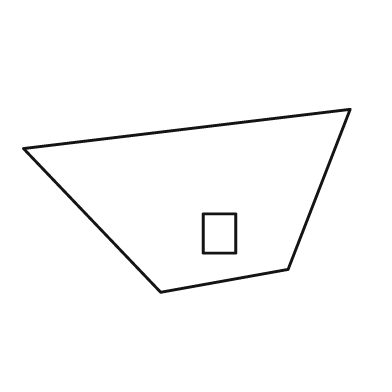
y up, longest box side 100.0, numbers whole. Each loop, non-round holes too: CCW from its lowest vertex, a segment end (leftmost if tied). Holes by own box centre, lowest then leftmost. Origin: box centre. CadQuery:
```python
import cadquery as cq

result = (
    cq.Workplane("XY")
    .moveTo(-8.0, -28.0)
    .lineTo(31.0, -21.0)
    .lineTo(50.0, 28.0)
    .lineTo(-50.0, 16.0)
    .close()
    .moveTo(5.0, -16.0)
    .lineTo(15.0, -16.0)
    .lineTo(15.0, -4.0)
    .lineTo(5.0, -4.0)
    .close()
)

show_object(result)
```